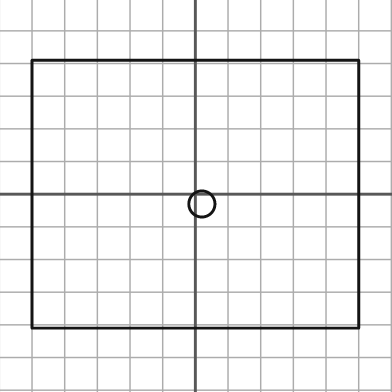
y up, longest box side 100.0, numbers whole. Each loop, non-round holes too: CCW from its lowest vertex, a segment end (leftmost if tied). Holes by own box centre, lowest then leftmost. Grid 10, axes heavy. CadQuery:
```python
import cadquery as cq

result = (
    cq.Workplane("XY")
    .moveTo(-50.0, -41.0)
    .lineTo(50.0, -41.0)
    .lineTo(50.0, 41.0)
    .lineTo(-50.0, 41.0)
    .close()
    .moveTo(2.0, -3.0)
    .circle(4.0)
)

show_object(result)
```